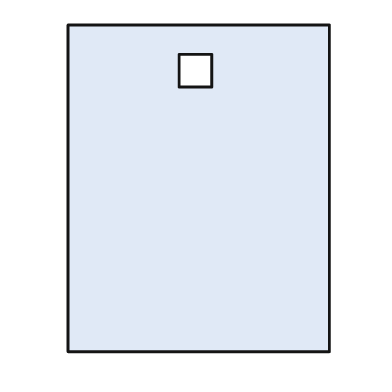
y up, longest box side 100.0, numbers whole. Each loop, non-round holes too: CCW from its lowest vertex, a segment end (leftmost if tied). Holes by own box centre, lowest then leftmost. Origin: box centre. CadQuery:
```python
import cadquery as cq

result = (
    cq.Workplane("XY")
    .moveTo(-40.0, -50.0)
    .lineTo(40.0, -50.0)
    .lineTo(40.0, 50.0)
    .lineTo(-40.0, 50.0)
    .close()
    .moveTo(-6.0, 31.0)
    .lineTo(4.0, 31.0)
    .lineTo(4.0, 41.0)
    .lineTo(-6.0, 41.0)
    .close()
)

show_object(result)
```